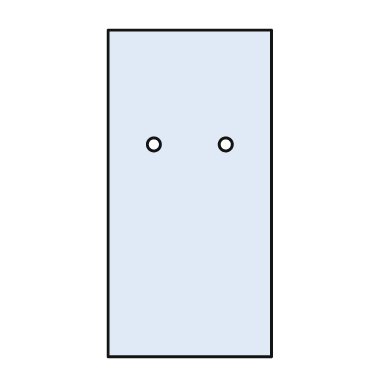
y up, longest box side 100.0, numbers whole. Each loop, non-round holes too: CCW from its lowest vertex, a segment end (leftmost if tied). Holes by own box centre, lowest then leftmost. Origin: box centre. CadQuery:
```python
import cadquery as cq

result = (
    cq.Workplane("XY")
    .moveTo(-25.0, -50.0)
    .lineTo(25.0, -50.0)
    .lineTo(25.0, 50.0)
    .lineTo(-25.0, 50.0)
    .close()
    .moveTo(-11.0, 15.0)
    .circle(2.0)
    .moveTo(11.0, 15.0)
    .circle(2.0)
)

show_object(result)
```